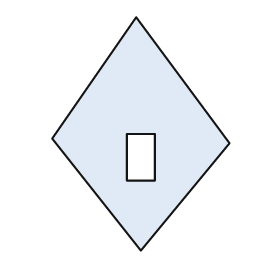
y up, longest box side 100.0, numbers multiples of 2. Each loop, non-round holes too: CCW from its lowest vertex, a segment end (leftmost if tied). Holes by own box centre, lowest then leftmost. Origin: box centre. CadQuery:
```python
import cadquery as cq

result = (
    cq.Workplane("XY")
    .moveTo(0.0, -50.0)
    .lineTo(38.0, -4.0)
    .lineTo(-2.0, 50.0)
    .lineTo(-38.0, -2.0)
    .close()
    .moveTo(-6.0, -20.0)
    .lineTo(6.0, -20.0)
    .lineTo(6.0, 0.0)
    .lineTo(-6.0, 0.0)
    .close()
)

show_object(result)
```